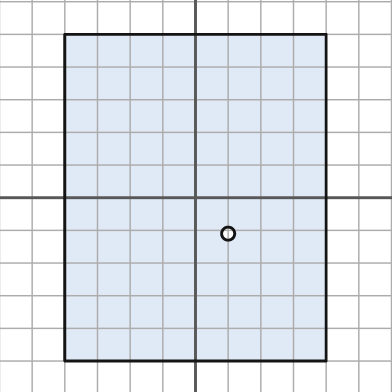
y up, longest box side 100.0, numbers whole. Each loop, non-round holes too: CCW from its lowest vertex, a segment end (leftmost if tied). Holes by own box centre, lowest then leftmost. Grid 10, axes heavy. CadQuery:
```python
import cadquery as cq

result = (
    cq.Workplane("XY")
    .moveTo(-40.0, -50.0)
    .lineTo(40.0, -50.0)
    .lineTo(40.0, 50.0)
    .lineTo(-40.0, 50.0)
    .close()
    .moveTo(10.0, -11.0)
    .circle(2.0)
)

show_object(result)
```